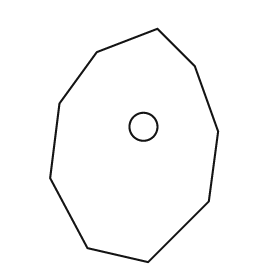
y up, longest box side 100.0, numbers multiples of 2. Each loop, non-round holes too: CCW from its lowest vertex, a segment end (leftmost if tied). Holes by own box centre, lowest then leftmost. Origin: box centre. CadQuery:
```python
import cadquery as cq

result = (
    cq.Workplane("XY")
    .moveTo(6.0, -50.0)
    .lineTo(32.0, -24.0)
    .lineTo(36.0, 6.0)
    .lineTo(26.0, 34.0)
    .lineTo(10.0, 50.0)
    .lineTo(-16.0, 40.0)
    .lineTo(-32.0, 18.0)
    .lineTo(-36.0, -14.0)
    .lineTo(-20.0, -44.0)
    .close()
    .moveTo(4.0, 8.0)
    .circle(6.0)
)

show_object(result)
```